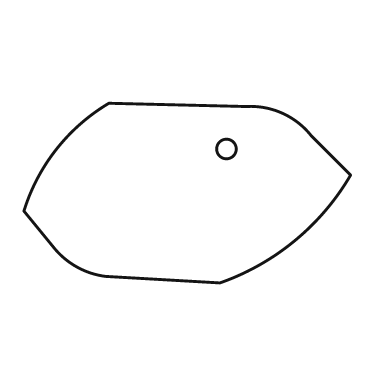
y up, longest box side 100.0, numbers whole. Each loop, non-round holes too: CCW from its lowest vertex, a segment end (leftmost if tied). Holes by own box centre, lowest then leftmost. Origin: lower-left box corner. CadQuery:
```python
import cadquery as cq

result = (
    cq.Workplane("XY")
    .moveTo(60.0, 0.0)
    .threePointArc((83.0, 13.0), (100.0, 33.0))
    .lineTo(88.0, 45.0)
    .threePointArc((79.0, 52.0), (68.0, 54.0))
    .lineTo(26.0, 55.0)
    .threePointArc((10.0, 41.0), (0.0, 22.0))
    .lineTo(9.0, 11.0)
    .threePointArc((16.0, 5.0), (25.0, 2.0))
    .close()
    .moveTo(62.0, 41.0)
    .circle(3.0)
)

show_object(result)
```